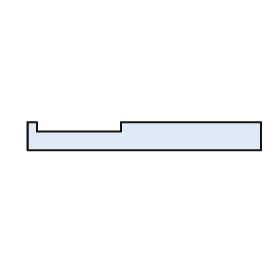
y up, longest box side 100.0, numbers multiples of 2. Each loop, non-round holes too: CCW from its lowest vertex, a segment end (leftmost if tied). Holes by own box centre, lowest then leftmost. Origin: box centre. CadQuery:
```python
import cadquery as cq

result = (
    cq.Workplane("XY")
    .moveTo(-50.0, -6.0)
    .lineTo(50.0, -6.0)
    .lineTo(50.0, 6.0)
    .lineTo(-10.0, 6.0)
    .lineTo(-10.0, 2.0)
    .lineTo(-46.0, 2.0)
    .lineTo(-46.0, 6.0)
    .lineTo(-50.0, 6.0)
    .close()
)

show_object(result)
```